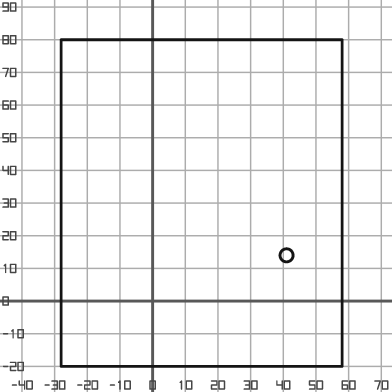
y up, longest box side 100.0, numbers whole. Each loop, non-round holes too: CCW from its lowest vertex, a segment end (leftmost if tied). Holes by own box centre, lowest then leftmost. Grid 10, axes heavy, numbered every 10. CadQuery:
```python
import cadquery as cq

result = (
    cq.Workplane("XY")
    .moveTo(-28.0, -20.0)
    .lineTo(58.0, -20.0)
    .lineTo(58.0, 80.0)
    .lineTo(-28.0, 80.0)
    .close()
    .moveTo(41.0, 14.0)
    .circle(2.0)
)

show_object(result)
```